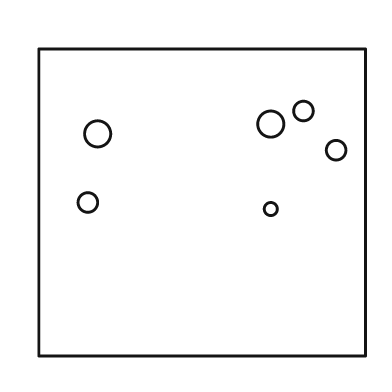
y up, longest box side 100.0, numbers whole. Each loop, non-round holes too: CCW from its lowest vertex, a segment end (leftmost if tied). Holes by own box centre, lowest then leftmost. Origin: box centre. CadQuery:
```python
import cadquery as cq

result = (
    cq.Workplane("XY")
    .moveTo(-50.0, -47.0)
    .lineTo(50.0, -47.0)
    .lineTo(50.0, 47.0)
    .lineTo(-50.0, 47.0)
    .close()
    .moveTo(21.0, -2.0)
    .circle(2.0)
    .moveTo(-35.0, 0.0)
    .circle(3.0)
    .moveTo(41.0, 16.0)
    .circle(3.0)
    .moveTo(-32.0, 21.0)
    .circle(4.0)
    .moveTo(21.0, 24.0)
    .circle(4.0)
    .moveTo(31.0, 28.0)
    .circle(3.0)
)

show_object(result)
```